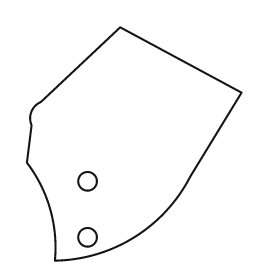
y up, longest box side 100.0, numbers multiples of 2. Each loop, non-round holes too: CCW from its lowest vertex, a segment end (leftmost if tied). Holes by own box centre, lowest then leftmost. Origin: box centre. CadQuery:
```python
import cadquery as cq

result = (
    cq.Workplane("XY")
    .moveTo(-34.0, -50.0)
    .threePointArc((0.0, -40.0), (24.0, -14.0))
    .lineTo(46.0, 22.0)
    .lineTo(-6.0, 50.0)
    .lineTo(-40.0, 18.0)
    .threePointArc((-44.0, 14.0), (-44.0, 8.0))
    .lineTo(-46.0, -8.0)
    .threePointArc((-36.0, -28.0), (-34.0, -50.0))
    .close()
    .moveTo(-20.0, -40.0)
    .circle(4.0)
    .moveTo(-20.0, -16.0)
    .circle(4.0)
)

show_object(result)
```